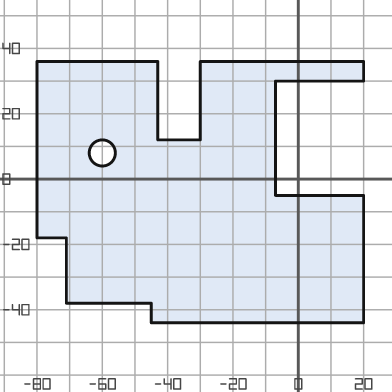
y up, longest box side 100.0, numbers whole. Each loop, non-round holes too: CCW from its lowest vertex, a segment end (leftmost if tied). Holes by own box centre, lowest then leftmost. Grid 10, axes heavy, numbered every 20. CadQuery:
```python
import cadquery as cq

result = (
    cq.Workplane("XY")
    .moveTo(-45.0, -44.0)
    .lineTo(20.0, -44.0)
    .lineTo(20.0, -5.0)
    .lineTo(-7.0, -5.0)
    .lineTo(-7.0, 30.0)
    .lineTo(20.0, 30.0)
    .lineTo(20.0, 36.0)
    .lineTo(-30.0, 36.0)
    .lineTo(-30.0, 12.0)
    .lineTo(-43.0, 12.0)
    .lineTo(-43.0, 36.0)
    .lineTo(-80.0, 36.0)
    .lineTo(-80.0, -18.0)
    .lineTo(-71.0, -18.0)
    .lineTo(-71.0, -38.0)
    .lineTo(-45.0, -38.0)
    .close()
    .moveTo(-60.0, 8.0)
    .circle(4.0)
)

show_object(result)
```